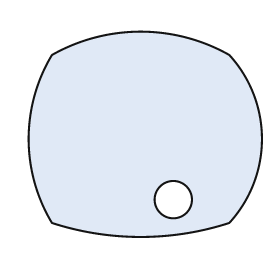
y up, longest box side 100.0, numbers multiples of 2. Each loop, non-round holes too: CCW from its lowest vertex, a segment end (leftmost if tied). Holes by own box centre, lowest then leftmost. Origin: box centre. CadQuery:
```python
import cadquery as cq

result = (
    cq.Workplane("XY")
    .moveTo(-40.0, -38.0)
    .threePointArc((-2.0, -44.0), (36.0, -38.0))
    .threePointArc((50.0, -2.0), (36.0, 34.0))
    .threePointArc((-2.0, 44.0), (-40.0, 34.0))
    .threePointArc((-50.0, -2.0), (-40.0, -38.0))
    .close()
    .moveTo(12.0, -28.0)
    .circle(8.0)
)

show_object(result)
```